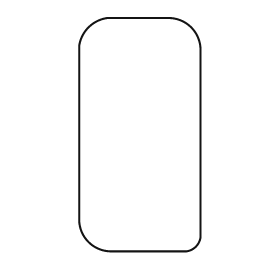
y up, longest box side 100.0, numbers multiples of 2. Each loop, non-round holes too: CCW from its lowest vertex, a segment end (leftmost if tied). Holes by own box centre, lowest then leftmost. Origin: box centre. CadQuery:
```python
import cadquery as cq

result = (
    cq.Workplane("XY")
    .moveTo(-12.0, -50.0)
    .lineTo(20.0, -50.0)
    .threePointArc((24.0, -48.0), (26.0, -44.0))
    .lineTo(26.0, 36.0)
    .threePointArc((22.0, 46.0), (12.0, 50.0))
    .lineTo(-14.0, 50.0)
    .threePointArc((-22.0, 46.0), (-26.0, 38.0))
    .lineTo(-26.0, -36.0)
    .threePointArc((-22.0, -46.0), (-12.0, -50.0))
    .close()
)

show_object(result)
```